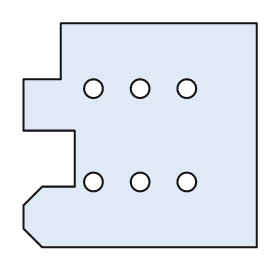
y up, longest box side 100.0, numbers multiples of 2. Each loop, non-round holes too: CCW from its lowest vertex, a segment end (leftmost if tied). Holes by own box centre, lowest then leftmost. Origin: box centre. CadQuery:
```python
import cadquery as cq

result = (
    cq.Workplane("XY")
    .moveTo(-42.0, -48.0)
    .lineTo(50.0, -48.0)
    .lineTo(50.0, 48.0)
    .lineTo(-34.0, 48.0)
    .lineTo(-34.0, 24.0)
    .lineTo(-50.0, 24.0)
    .lineTo(-50.0, 2.0)
    .lineTo(-28.0, 2.0)
    .lineTo(-28.0, -22.0)
    .lineTo(-42.0, -22.0)
    .lineTo(-50.0, -30.0)
    .lineTo(-50.0, -40.0)
    .close()
    .moveTo(-20.0, -20.0)
    .circle(4.0)
    .moveTo(0.0, -20.0)
    .circle(4.0)
    .moveTo(20.0, -20.0)
    .circle(4.0)
    .moveTo(-20.0, 20.0)
    .circle(4.0)
    .moveTo(0.0, 20.0)
    .circle(4.0)
    .moveTo(20.0, 20.0)
    .circle(4.0)
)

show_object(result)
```